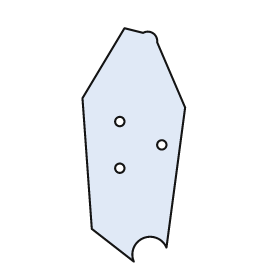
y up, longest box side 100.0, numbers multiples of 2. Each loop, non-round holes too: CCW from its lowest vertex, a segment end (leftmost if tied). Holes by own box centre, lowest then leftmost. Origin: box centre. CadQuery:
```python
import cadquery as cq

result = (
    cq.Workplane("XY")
    .moveTo(0.0, -50.0)
    .threePointArc((4.0, -40.0), (14.0, -44.0))
    .lineTo(22.0, 16.0)
    .lineTo(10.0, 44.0)
    .threePointArc((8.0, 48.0), (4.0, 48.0))
    .lineTo(-4.0, 50.0)
    .lineTo(-22.0, 20.0)
    .lineTo(-18.0, -36.0)
    .close()
    .moveTo(-6.0, -10.0)
    .circle(2.0)
    .moveTo(12.0, 0.0)
    .circle(2.0)
    .moveTo(-6.0, 10.0)
    .circle(2.0)
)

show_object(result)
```